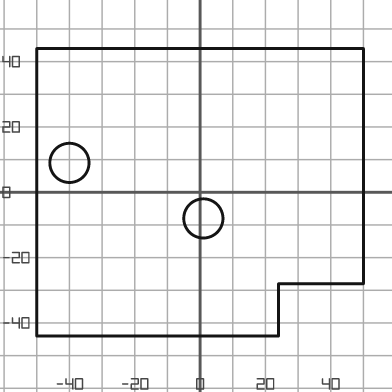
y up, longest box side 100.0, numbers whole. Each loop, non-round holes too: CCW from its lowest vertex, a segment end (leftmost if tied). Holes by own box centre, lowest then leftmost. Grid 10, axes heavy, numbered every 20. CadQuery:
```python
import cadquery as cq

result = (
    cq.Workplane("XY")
    .moveTo(-50.0, -44.0)
    .lineTo(24.0, -44.0)
    .lineTo(24.0, -28.0)
    .lineTo(50.0, -28.0)
    .lineTo(50.0, 44.0)
    .lineTo(-50.0, 44.0)
    .close()
    .moveTo(1.0, -8.0)
    .circle(6.0)
    .moveTo(-40.0, 9.0)
    .circle(6.0)
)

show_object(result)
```